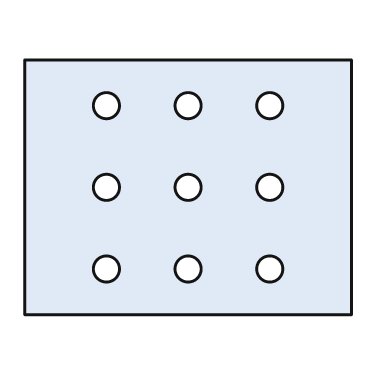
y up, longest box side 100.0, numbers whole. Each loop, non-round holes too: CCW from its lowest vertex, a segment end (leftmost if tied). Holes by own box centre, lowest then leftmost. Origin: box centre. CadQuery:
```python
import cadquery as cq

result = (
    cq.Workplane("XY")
    .moveTo(-50.0, -39.0)
    .lineTo(50.0, -39.0)
    .lineTo(50.0, 39.0)
    .lineTo(-50.0, 39.0)
    .close()
    .moveTo(-25.0, -25.0)
    .circle(4.0)
    .moveTo(0.0, -25.0)
    .circle(4.0)
    .moveTo(25.0, -25.0)
    .circle(4.0)
    .moveTo(-25.0, 0.0)
    .circle(4.0)
    .moveTo(0.0, 0.0)
    .circle(4.0)
    .moveTo(25.0, 0.0)
    .circle(4.0)
    .moveTo(-25.0, 25.0)
    .circle(4.0)
    .moveTo(0.0, 25.0)
    .circle(4.0)
    .moveTo(25.0, 25.0)
    .circle(4.0)
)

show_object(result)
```